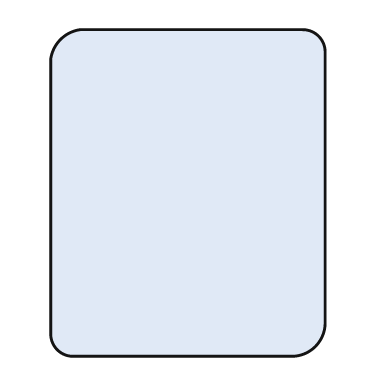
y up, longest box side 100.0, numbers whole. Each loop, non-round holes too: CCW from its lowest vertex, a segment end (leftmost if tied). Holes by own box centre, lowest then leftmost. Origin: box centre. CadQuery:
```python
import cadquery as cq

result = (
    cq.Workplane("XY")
    .moveTo(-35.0, -50.0)
    .lineTo(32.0, -50.0)
    .threePointArc((39.0, -47.0), (42.0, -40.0))
    .lineTo(42.0, 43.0)
    .threePointArc((40.0, 48.0), (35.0, 50.0))
    .lineTo(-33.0, 50.0)
    .threePointArc((-39.0, 47.0), (-42.0, 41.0))
    .lineTo(-42.0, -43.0)
    .threePointArc((-40.0, -48.0), (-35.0, -50.0))
    .close()
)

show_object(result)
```